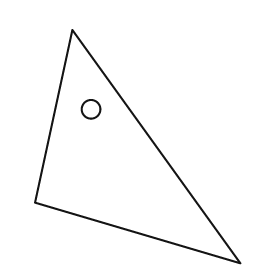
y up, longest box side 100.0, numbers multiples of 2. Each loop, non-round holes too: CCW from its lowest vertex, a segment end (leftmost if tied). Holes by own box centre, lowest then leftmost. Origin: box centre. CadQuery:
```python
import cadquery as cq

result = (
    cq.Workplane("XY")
    .moveTo(44.0, -50.0)
    .lineTo(-28.0, 50.0)
    .lineTo(-44.0, -24.0)
    .close()
    .moveTo(-20.0, 16.0)
    .circle(4.0)
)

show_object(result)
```